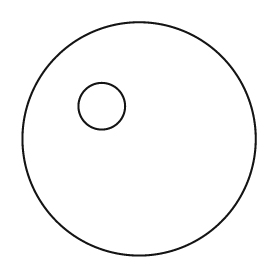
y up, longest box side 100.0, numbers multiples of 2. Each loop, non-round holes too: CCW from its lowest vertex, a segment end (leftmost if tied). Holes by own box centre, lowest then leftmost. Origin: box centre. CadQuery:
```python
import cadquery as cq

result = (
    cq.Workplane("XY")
    .moveTo(0.0, 0.0)
    .circle(50.0)
    .moveTo(-16.0, 14.0)
    .circle(10.0)
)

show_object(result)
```